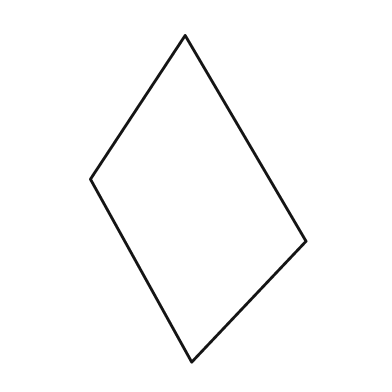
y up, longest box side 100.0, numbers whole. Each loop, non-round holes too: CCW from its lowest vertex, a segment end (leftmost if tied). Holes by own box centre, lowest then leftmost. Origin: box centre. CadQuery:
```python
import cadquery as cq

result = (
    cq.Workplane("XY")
    .moveTo(-2.0, -50.0)
    .lineTo(33.0, -13.0)
    .lineTo(-4.0, 50.0)
    .lineTo(-33.0, 6.0)
    .close()
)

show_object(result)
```